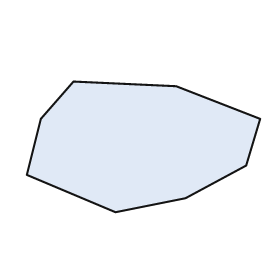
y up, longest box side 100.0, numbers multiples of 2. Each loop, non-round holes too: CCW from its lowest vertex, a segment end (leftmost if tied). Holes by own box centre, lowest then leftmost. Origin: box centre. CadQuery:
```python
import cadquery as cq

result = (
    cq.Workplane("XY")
    .moveTo(-12.0, -28.0)
    .lineTo(18.0, -22.0)
    .lineTo(44.0, -8.0)
    .lineTo(50.0, 12.0)
    .lineTo(14.0, 26.0)
    .lineTo(-30.0, 28.0)
    .lineTo(-44.0, 12.0)
    .lineTo(-50.0, -12.0)
    .close()
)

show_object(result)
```